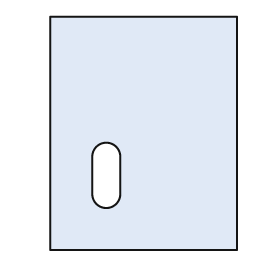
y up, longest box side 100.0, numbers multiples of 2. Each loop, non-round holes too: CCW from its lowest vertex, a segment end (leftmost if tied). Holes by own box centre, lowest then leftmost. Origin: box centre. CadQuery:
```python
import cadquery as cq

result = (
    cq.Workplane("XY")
    .moveTo(-40.0, -50.0)
    .lineTo(40.0, -50.0)
    .lineTo(40.0, 50.0)
    .lineTo(-40.0, 50.0)
    .close()
    .moveTo(-22.0, -26.0)
    .threePointArc((-16.0, -32.0), (-10.0, -26.0))
    .lineTo(-10.0, -10.0)
    .threePointArc((-16.0, -4.0), (-22.0, -10.0))
    .close()
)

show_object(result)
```